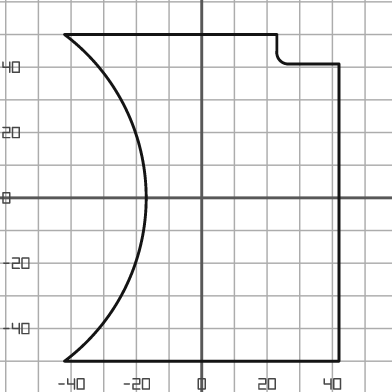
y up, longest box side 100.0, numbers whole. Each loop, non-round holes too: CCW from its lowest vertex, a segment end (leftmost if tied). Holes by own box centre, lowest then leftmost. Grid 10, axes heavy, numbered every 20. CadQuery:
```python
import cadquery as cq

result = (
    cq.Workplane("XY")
    .moveTo(-42.0, -50.0)
    .lineTo(42.0, -50.0)
    .lineTo(42.0, 41.0)
    .lineTo(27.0, 41.0)
    .threePointArc((24.0, 42.0), (23.0, 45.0))
    .lineTo(23.0, 50.0)
    .lineTo(-42.0, 50.0)
    .threePointArc((-17.0, 0.0), (-42.0, -50.0))
    .close()
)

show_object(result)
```